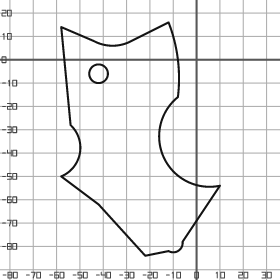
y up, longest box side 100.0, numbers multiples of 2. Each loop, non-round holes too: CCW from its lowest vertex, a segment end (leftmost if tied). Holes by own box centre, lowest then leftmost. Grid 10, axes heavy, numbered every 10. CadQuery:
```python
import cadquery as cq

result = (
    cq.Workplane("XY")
    .moveTo(-22.0, -84.0)
    .lineTo(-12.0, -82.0)
    .threePointArc((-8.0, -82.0), (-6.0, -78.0))
    .lineTo(10.0, -54.0)
    .threePointArc((-14.0, -42.0), (-8.0, -16.0))
    .threePointArc((-8.0, 0.0), (-12.0, 16.0))
    .lineTo(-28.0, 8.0)
    .threePointArc((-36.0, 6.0), (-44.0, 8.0))
    .lineTo(-58.0, 14.0)
    .lineTo(-54.0, -28.0)
    .threePointArc((-50.0, -40.0), (-58.0, -50.0))
    .lineTo(-42.0, -62.0)
    .close()
    .moveTo(-42.0, -6.0)
    .circle(4.0)
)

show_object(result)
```